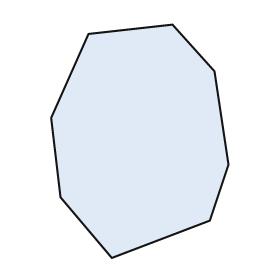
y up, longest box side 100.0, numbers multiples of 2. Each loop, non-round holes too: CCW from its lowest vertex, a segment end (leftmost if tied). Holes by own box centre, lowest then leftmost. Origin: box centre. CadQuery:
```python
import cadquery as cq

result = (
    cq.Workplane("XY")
    .moveTo(-12.0, -50.0)
    .lineTo(30.0, -34.0)
    .lineTo(38.0, -10.0)
    .lineTo(32.0, 30.0)
    .lineTo(14.0, 50.0)
    .lineTo(-22.0, 46.0)
    .lineTo(-38.0, 10.0)
    .lineTo(-34.0, -24.0)
    .close()
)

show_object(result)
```